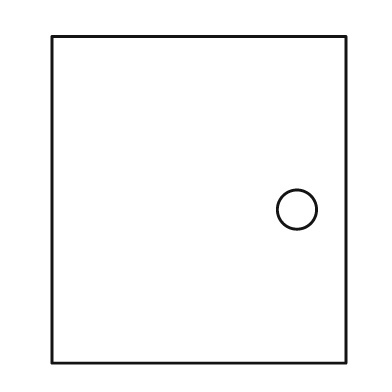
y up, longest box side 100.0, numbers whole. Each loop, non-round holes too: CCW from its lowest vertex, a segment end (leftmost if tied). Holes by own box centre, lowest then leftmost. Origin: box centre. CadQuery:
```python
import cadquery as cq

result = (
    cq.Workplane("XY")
    .moveTo(-45.0, -50.0)
    .lineTo(45.0, -50.0)
    .lineTo(45.0, 50.0)
    .lineTo(-45.0, 50.0)
    .close()
    .moveTo(30.0, -3.0)
    .circle(6.0)
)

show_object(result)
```